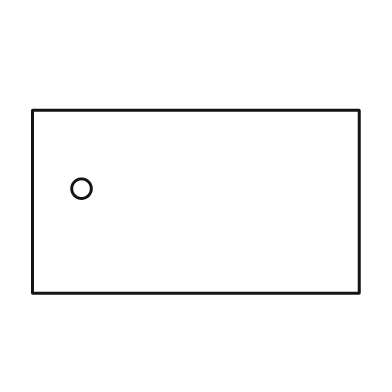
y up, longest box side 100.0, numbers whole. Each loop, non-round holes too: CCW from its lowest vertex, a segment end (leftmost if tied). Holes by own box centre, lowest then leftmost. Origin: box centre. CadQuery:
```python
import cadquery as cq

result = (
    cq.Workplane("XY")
    .moveTo(-50.0, -28.0)
    .lineTo(50.0, -28.0)
    .lineTo(50.0, 28.0)
    .lineTo(-50.0, 28.0)
    .close()
    .moveTo(-35.0, 4.0)
    .circle(3.0)
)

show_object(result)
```